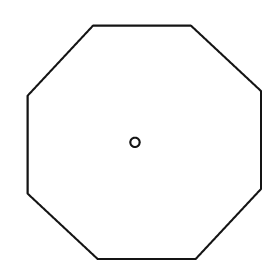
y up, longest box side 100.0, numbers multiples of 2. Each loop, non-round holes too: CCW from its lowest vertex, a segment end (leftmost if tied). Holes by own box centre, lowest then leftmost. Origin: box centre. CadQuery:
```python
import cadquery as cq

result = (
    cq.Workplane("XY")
    .moveTo(-20.0, -50.0)
    .lineTo(22.0, -50.0)
    .lineTo(50.0, -20.0)
    .lineTo(50.0, 22.0)
    .lineTo(20.0, 50.0)
    .lineTo(-22.0, 50.0)
    .lineTo(-50.0, 20.0)
    .lineTo(-50.0, -22.0)
    .close()
    .moveTo(-4.0, 0.0)
    .circle(2.0)
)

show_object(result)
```